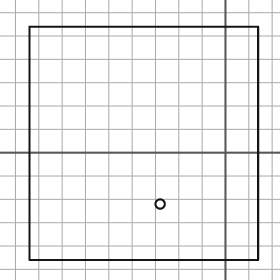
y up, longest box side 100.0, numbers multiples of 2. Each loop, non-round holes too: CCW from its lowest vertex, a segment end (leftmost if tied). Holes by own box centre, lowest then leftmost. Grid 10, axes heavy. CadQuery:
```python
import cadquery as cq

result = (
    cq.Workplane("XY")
    .moveTo(-84.0, -46.0)
    .lineTo(14.0, -46.0)
    .lineTo(14.0, 54.0)
    .lineTo(-84.0, 54.0)
    .close()
    .moveTo(-28.0, -22.0)
    .circle(2.0)
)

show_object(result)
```